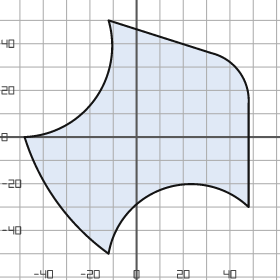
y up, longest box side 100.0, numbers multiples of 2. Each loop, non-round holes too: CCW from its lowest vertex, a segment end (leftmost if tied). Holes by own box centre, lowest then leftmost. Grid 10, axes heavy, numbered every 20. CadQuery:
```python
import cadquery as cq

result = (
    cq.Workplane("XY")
    .moveTo(-12.0, -50.0)
    .threePointArc((12.0, -22.0), (48.0, -30.0))
    .lineTo(48.0, 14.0)
    .threePointArc((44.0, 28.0), (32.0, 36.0))
    .lineTo(-12.0, 50.0)
    .threePointArc((-18.0, 16.0), (-48.0, 0.0))
    .threePointArc((-34.0, -28.0), (-12.0, -50.0))
    .close()
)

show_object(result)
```